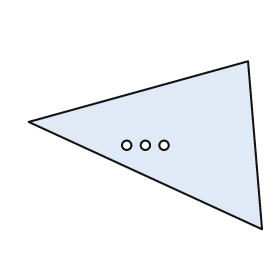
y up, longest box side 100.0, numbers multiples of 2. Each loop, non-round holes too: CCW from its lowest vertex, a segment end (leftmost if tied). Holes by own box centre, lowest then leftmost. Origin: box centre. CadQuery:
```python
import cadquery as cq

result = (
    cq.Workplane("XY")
    .moveTo(50.0, -36.0)
    .lineTo(44.0, 36.0)
    .lineTo(-50.0, 10.0)
    .close()
    .moveTo(-8.0, 0.0)
    .circle(2.0)
    .moveTo(0.0, 0.0)
    .circle(2.0)
    .moveTo(8.0, 0.0)
    .circle(2.0)
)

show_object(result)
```